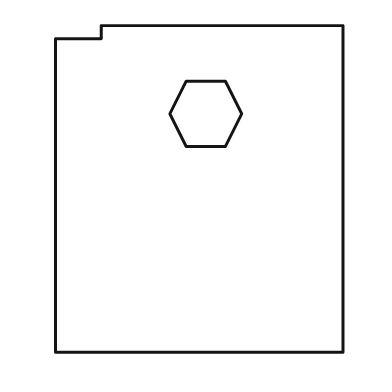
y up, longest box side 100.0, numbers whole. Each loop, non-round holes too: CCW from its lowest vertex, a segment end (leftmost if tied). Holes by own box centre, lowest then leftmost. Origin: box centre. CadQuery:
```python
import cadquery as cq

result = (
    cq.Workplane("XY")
    .moveTo(-44.0, -50.0)
    .lineTo(44.0, -50.0)
    .lineTo(44.0, 50.0)
    .lineTo(-30.0, 50.0)
    .lineTo(-30.0, 46.0)
    .lineTo(-44.0, 46.0)
    .close()
    .moveTo(-4.0, 13.0)
    .lineTo(8.0, 13.0)
    .lineTo(13.0, 23.0)
    .lineTo(8.0, 33.0)
    .lineTo(-4.0, 33.0)
    .lineTo(-9.0, 23.0)
    .close()
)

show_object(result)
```